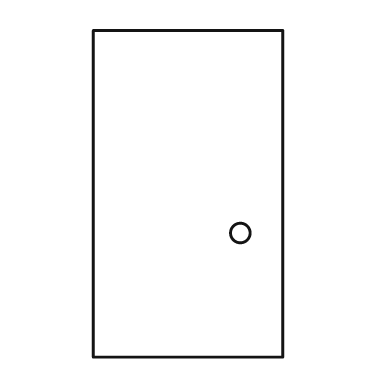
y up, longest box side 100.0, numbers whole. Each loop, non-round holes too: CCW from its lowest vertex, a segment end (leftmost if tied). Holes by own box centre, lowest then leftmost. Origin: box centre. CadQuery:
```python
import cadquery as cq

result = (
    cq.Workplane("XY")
    .moveTo(-29.0, -50.0)
    .lineTo(29.0, -50.0)
    .lineTo(29.0, 50.0)
    .lineTo(-29.0, 50.0)
    .close()
    .moveTo(16.0, -12.0)
    .circle(3.0)
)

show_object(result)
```